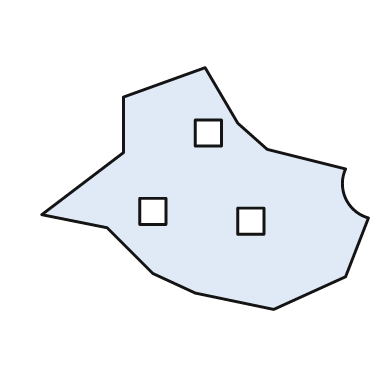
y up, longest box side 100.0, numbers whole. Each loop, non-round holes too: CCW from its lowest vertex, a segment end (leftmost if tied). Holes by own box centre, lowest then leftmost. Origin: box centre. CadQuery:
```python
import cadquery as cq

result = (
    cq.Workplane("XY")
    .moveTo(21.0, -37.0)
    .lineTo(43.0, -27.0)
    .lineTo(50.0, -9.0)
    .threePointArc((43.0, -3.0), (43.0, 6.0))
    .lineTo(19.0, 12.0)
    .lineTo(10.0, 20.0)
    .lineTo(0.0, 37.0)
    .lineTo(-25.0, 28.0)
    .lineTo(-25.0, 11.0)
    .lineTo(-50.0, -8.0)
    .lineTo(-30.0, -12.0)
    .lineTo(-16.0, -26.0)
    .lineTo(-3.0, -32.0)
    .close()
    .moveTo(10.0, -14.0)
    .lineTo(18.0, -14.0)
    .lineTo(18.0, -6.0)
    .lineTo(10.0, -6.0)
    .close()
    .moveTo(-20.0, -11.0)
    .lineTo(-12.0, -11.0)
    .lineTo(-12.0, -3.0)
    .lineTo(-20.0, -3.0)
    .close()
    .moveTo(-3.0, 13.0)
    .lineTo(5.0, 13.0)
    .lineTo(5.0, 21.0)
    .lineTo(-3.0, 21.0)
    .close()
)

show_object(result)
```